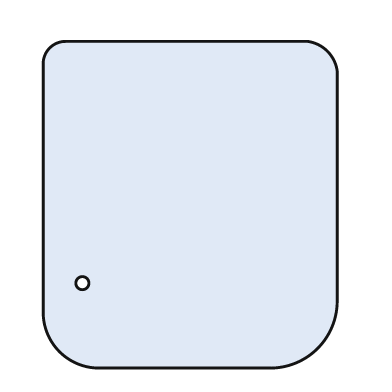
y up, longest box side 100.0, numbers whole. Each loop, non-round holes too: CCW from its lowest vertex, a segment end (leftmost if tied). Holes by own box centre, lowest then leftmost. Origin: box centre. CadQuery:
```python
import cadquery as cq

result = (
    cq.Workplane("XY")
    .moveTo(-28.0, -50.0)
    .lineTo(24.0, -50.0)
    .threePointArc((39.0, -44.0), (45.0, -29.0))
    .lineTo(45.0, 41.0)
    .threePointArc((42.0, 47.0), (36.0, 50.0))
    .lineTo(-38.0, 50.0)
    .threePointArc((-43.0, 48.0), (-45.0, 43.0))
    .lineTo(-45.0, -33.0)
    .threePointArc((-40.0, -45.0), (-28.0, -50.0))
    .close()
    .moveTo(-33.0, -24.0)
    .circle(2.0)
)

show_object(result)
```